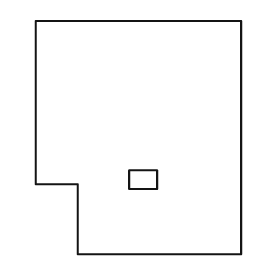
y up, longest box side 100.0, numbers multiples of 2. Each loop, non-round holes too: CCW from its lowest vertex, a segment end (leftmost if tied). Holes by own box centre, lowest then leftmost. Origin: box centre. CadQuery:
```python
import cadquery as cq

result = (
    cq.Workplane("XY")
    .moveTo(-26.0, -50.0)
    .lineTo(44.0, -50.0)
    .lineTo(44.0, 50.0)
    .lineTo(-44.0, 50.0)
    .lineTo(-44.0, -20.0)
    .lineTo(-26.0, -20.0)
    .close()
    .moveTo(-4.0, -22.0)
    .lineTo(8.0, -22.0)
    .lineTo(8.0, -14.0)
    .lineTo(-4.0, -14.0)
    .close()
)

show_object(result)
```